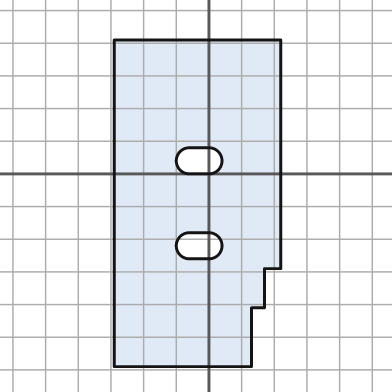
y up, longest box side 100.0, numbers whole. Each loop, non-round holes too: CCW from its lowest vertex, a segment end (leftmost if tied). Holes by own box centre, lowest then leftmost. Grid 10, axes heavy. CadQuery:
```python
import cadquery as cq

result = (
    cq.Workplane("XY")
    .moveTo(-29.0, -59.0)
    .lineTo(13.0, -59.0)
    .lineTo(13.0, -41.0)
    .lineTo(17.0, -41.0)
    .lineTo(17.0, -29.0)
    .lineTo(22.0, -29.0)
    .lineTo(22.0, 41.0)
    .lineTo(-29.0, 41.0)
    .close()
    .moveTo(-6.0, -26.0)
    .lineTo(0.0, -26.0)
    .threePointArc((4.0, -22.0), (0.0, -18.0))
    .lineTo(-6.0, -18.0)
    .threePointArc((-10.0, -22.0), (-6.0, -26.0))
    .close()
    .moveTo(-6.0, 0.0)
    .lineTo(0.0, 0.0)
    .threePointArc((4.0, 4.0), (0.0, 8.0))
    .lineTo(-6.0, 8.0)
    .threePointArc((-10.0, 4.0), (-6.0, 0.0))
    .close()
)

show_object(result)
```